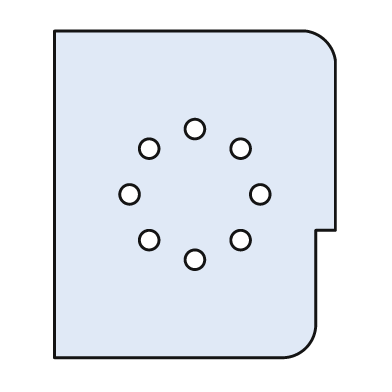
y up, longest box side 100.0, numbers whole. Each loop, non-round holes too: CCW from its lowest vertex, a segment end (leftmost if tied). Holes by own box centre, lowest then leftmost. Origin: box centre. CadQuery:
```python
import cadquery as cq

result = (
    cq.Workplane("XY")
    .moveTo(-43.0, -50.0)
    .lineTo(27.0, -50.0)
    .threePointArc((34.0, -47.0), (37.0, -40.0))
    .lineTo(37.0, -11.0)
    .lineTo(43.0, -11.0)
    .lineTo(43.0, 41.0)
    .threePointArc((40.0, 47.0), (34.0, 50.0))
    .lineTo(-43.0, 50.0)
    .close()
    .moveTo(0.0, -20.0)
    .circle(3.0)
    .moveTo(-14.0, -14.0)
    .circle(3.0)
    .moveTo(14.0, -14.0)
    .circle(3.0)
    .moveTo(-20.0, 0.0)
    .circle(3.0)
    .moveTo(20.0, 0.0)
    .circle(3.0)
    .moveTo(-14.0, 14.0)
    .circle(3.0)
    .moveTo(14.0, 14.0)
    .circle(3.0)
    .moveTo(0.0, 20.0)
    .circle(3.0)
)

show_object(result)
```